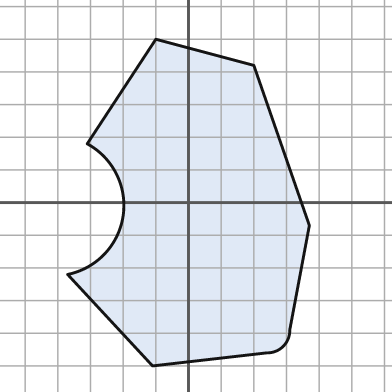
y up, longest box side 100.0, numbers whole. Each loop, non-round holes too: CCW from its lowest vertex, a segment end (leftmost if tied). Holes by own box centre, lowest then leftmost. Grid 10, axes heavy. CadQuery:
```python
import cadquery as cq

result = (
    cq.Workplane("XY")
    .moveTo(-11.0, -50.0)
    .lineTo(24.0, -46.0)
    .threePointArc((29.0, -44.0), (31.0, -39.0))
    .lineTo(37.0, -7.0)
    .lineTo(20.0, 42.0)
    .lineTo(-10.0, 50.0)
    .lineTo(-31.0, 18.0)
    .threePointArc((-20.0, -4.0), (-37.0, -22.0))
    .close()
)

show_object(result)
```